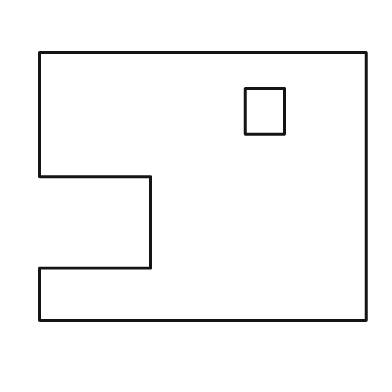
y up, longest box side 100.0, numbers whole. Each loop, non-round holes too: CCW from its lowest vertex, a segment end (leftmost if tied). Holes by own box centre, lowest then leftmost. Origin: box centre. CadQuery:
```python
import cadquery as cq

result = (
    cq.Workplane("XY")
    .moveTo(-50.0, -41.0)
    .lineTo(50.0, -41.0)
    .lineTo(50.0, 41.0)
    .lineTo(-50.0, 41.0)
    .lineTo(-50.0, 3.0)
    .lineTo(-16.0, 3.0)
    .lineTo(-16.0, -25.0)
    .lineTo(-50.0, -25.0)
    .close()
    .moveTo(13.0, 16.0)
    .lineTo(25.0, 16.0)
    .lineTo(25.0, 30.0)
    .lineTo(13.0, 30.0)
    .close()
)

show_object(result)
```